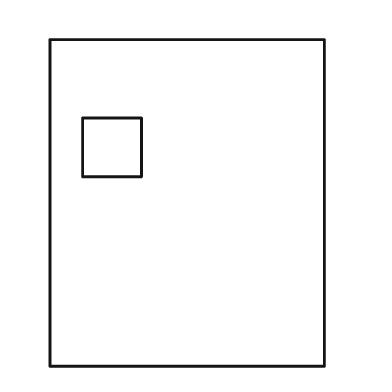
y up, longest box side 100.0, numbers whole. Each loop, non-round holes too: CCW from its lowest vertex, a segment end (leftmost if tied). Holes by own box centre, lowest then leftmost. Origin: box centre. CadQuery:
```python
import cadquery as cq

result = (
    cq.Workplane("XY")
    .moveTo(-42.0, -50.0)
    .lineTo(42.0, -50.0)
    .lineTo(42.0, 50.0)
    .lineTo(-42.0, 50.0)
    .close()
    .moveTo(-32.0, 8.0)
    .lineTo(-14.0, 8.0)
    .lineTo(-14.0, 26.0)
    .lineTo(-32.0, 26.0)
    .close()
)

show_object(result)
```